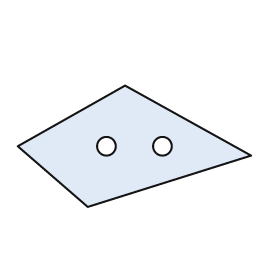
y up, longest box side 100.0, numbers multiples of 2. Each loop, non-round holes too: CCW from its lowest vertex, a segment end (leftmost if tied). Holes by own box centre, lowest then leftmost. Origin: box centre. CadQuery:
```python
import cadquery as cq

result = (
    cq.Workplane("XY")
    .moveTo(-20.0, -26.0)
    .lineTo(50.0, -4.0)
    .lineTo(-4.0, 26.0)
    .lineTo(-50.0, 0.0)
    .close()
    .moveTo(-12.0, 0.0)
    .circle(4.0)
    .moveTo(12.0, 0.0)
    .circle(4.0)
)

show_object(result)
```